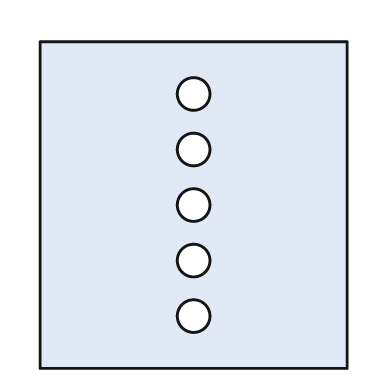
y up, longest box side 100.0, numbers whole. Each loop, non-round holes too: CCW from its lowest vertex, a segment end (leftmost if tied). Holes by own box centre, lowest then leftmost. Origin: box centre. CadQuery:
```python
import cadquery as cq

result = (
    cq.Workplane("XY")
    .moveTo(-47.0, -50.0)
    .lineTo(47.0, -50.0)
    .lineTo(47.0, 50.0)
    .lineTo(-47.0, 50.0)
    .close()
    .moveTo(0.0, -34.0)
    .circle(5.0)
    .moveTo(0.0, -17.0)
    .circle(5.0)
    .moveTo(0.0, 0.0)
    .circle(5.0)
    .moveTo(0.0, 17.0)
    .circle(5.0)
    .moveTo(0.0, 34.0)
    .circle(5.0)
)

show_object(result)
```